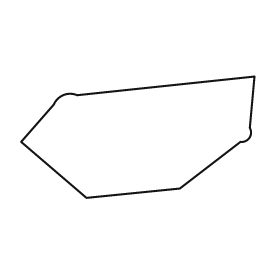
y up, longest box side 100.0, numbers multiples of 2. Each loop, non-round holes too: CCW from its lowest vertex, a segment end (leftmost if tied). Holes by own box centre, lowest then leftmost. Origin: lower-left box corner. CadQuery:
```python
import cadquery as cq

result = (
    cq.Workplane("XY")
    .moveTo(28.0, 0.0)
    .lineTo(68.0, 4.0)
    .lineTo(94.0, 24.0)
    .threePointArc((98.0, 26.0), (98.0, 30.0))
    .lineTo(100.0, 52.0)
    .lineTo(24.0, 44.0)
    .threePointArc((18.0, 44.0), (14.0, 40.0))
    .lineTo(0.0, 24.0)
    .close()
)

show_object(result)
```